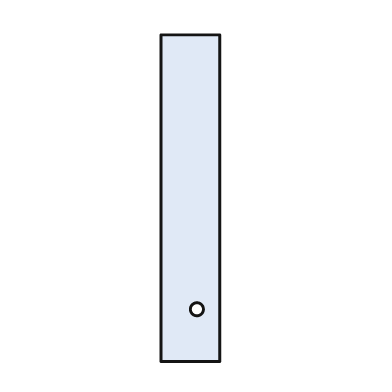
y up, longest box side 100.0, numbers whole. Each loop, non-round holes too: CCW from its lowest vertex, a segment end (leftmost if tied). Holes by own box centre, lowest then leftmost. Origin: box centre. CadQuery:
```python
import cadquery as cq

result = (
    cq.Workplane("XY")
    .moveTo(-9.0, -50.0)
    .lineTo(9.0, -50.0)
    .lineTo(9.0, 50.0)
    .lineTo(-9.0, 50.0)
    .close()
    .moveTo(2.0, -34.0)
    .circle(2.0)
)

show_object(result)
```